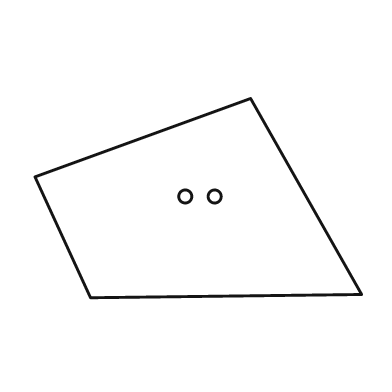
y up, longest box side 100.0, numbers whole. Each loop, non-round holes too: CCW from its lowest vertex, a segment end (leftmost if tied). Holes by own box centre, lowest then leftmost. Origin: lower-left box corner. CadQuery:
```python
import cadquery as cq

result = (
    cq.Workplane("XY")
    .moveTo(17.0, 0.0)
    .lineTo(100.0, 1.0)
    .lineTo(66.0, 61.0)
    .lineTo(0.0, 37.0)
    .close()
    .moveTo(46.0, 31.0)
    .circle(2.0)
    .moveTo(55.0, 31.0)
    .circle(2.0)
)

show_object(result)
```